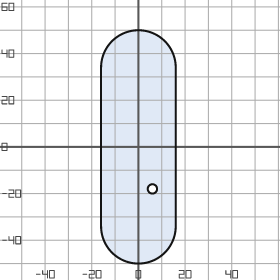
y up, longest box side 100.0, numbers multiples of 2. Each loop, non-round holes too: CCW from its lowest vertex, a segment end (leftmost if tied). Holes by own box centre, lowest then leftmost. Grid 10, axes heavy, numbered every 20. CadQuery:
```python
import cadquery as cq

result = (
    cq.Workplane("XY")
    .moveTo(-16.0, -34.0)
    .threePointArc((0.0, -50.0), (16.0, -34.0))
    .lineTo(16.0, 34.0)
    .threePointArc((0.0, 50.0), (-16.0, 34.0))
    .close()
    .moveTo(6.0, -18.0)
    .circle(2.0)
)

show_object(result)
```